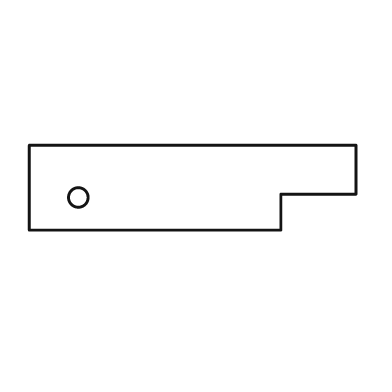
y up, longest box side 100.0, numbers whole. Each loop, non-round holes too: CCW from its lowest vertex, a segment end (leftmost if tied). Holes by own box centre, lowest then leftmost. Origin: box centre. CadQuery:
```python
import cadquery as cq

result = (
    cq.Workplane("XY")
    .moveTo(-50.0, -13.0)
    .lineTo(27.0, -13.0)
    .lineTo(27.0, -2.0)
    .lineTo(50.0, -2.0)
    .lineTo(50.0, 13.0)
    .lineTo(-50.0, 13.0)
    .close()
    .moveTo(-35.0, -3.0)
    .circle(3.0)
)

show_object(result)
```